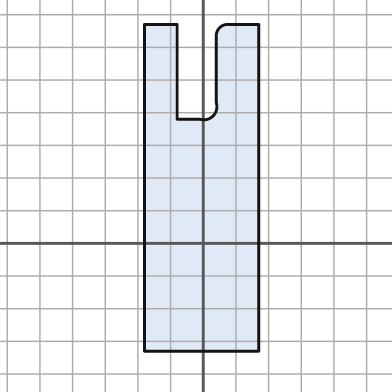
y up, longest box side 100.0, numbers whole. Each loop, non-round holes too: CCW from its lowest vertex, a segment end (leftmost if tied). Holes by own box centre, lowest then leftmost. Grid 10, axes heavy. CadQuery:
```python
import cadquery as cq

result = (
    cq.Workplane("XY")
    .moveTo(-18.0, -33.0)
    .lineTo(17.0, -33.0)
    .lineTo(17.0, 67.0)
    .lineTo(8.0, 67.0)
    .threePointArc((5.0, 66.0), (4.0, 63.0))
    .lineTo(4.0, 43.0)
    .threePointArc((3.0, 39.0), (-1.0, 38.0))
    .lineTo(-8.0, 38.0)
    .lineTo(-8.0, 67.0)
    .lineTo(-18.0, 67.0)
    .close()
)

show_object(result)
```